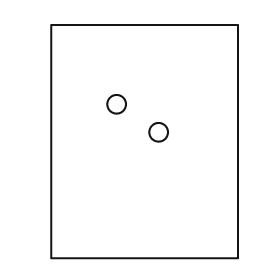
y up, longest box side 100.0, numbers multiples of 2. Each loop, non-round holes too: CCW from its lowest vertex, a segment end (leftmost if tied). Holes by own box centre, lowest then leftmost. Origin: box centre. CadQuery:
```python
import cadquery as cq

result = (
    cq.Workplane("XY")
    .moveTo(-40.0, -50.0)
    .lineTo(40.0, -50.0)
    .lineTo(40.0, 50.0)
    .lineTo(-40.0, 50.0)
    .close()
    .moveTo(6.0, 4.0)
    .circle(4.0)
    .moveTo(-12.0, 16.0)
    .circle(4.0)
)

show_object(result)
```